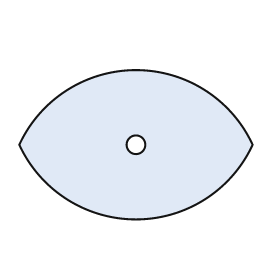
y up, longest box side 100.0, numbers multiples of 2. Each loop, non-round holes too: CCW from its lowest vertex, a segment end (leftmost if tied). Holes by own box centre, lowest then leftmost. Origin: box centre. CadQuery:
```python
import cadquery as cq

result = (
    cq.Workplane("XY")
    .moveTo(-50.0, 0.0)
    .threePointArc((0.0, -32.0), (50.0, 0.0))
    .threePointArc((0.0, 32.0), (-50.0, 0.0))
    .close()
    .moveTo(0.0, 0.0)
    .circle(4.0)
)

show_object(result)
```